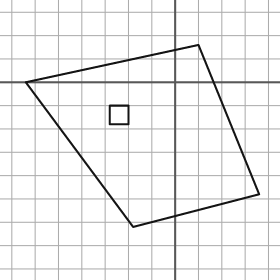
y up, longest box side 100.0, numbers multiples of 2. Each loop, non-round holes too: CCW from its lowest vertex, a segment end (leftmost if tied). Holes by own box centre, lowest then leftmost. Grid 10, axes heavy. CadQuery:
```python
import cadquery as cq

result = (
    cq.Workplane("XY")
    .moveTo(-18.0, -62.0)
    .lineTo(36.0, -48.0)
    .lineTo(10.0, 16.0)
    .lineTo(-64.0, 0.0)
    .close()
    .moveTo(-28.0, -18.0)
    .lineTo(-20.0, -18.0)
    .lineTo(-20.0, -10.0)
    .lineTo(-28.0, -10.0)
    .close()
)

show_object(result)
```